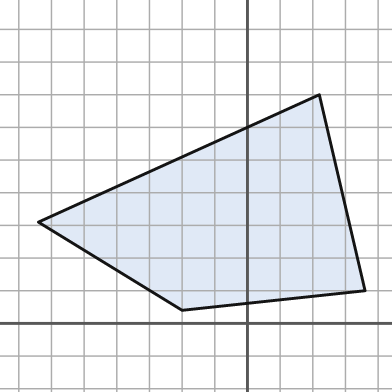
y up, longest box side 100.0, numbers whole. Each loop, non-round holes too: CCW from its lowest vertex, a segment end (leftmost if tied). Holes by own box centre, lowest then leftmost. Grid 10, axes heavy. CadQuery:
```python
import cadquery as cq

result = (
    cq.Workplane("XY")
    .moveTo(-20.0, 4.0)
    .lineTo(36.0, 10.0)
    .lineTo(22.0, 70.0)
    .lineTo(-64.0, 31.0)
    .close()
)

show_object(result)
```